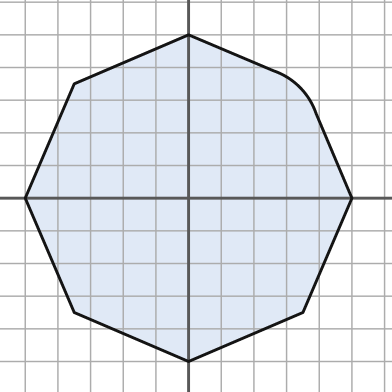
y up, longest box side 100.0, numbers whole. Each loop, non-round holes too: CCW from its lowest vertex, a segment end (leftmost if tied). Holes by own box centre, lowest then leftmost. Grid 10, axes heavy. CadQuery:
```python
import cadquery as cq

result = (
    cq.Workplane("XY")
    .moveTo(0.0, -50.0)
    .lineTo(35.0, -35.0)
    .lineTo(50.0, 0.0)
    .lineTo(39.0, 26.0)
    .threePointArc((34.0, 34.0), (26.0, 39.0))
    .lineTo(0.0, 50.0)
    .lineTo(-35.0, 35.0)
    .lineTo(-50.0, 0.0)
    .lineTo(-35.0, -35.0)
    .close()
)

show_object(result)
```